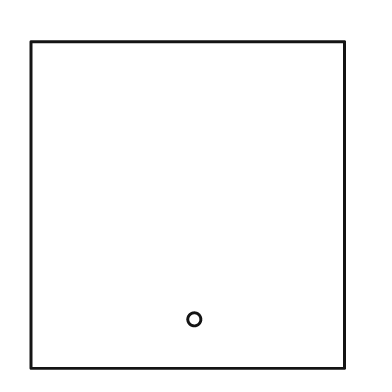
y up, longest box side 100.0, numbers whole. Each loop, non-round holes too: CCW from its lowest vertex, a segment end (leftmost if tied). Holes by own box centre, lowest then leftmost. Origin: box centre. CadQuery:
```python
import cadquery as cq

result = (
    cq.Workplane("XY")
    .moveTo(-48.0, -50.0)
    .lineTo(48.0, -50.0)
    .lineTo(48.0, 50.0)
    .lineTo(-48.0, 50.0)
    .close()
    .moveTo(2.0, -35.0)
    .circle(2.0)
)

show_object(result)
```